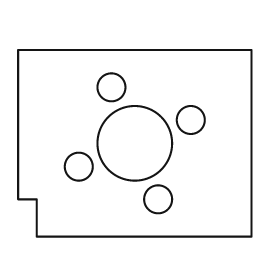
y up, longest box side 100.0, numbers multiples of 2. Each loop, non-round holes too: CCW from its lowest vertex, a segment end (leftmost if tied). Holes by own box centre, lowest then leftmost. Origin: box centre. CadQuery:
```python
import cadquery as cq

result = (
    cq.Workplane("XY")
    .moveTo(-42.0, -40.0)
    .lineTo(50.0, -40.0)
    .lineTo(50.0, 40.0)
    .lineTo(-50.0, 40.0)
    .lineTo(-50.0, -24.0)
    .lineTo(-42.0, -24.0)
    .close()
    .moveTo(10.0, -24.0)
    .circle(6.0)
    .moveTo(-24.0, -10.0)
    .circle(6.0)
    .moveTo(0.0, 0.0)
    .circle(16.0)
    .moveTo(24.0, 10.0)
    .circle(6.0)
    .moveTo(-10.0, 24.0)
    .circle(6.0)
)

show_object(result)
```